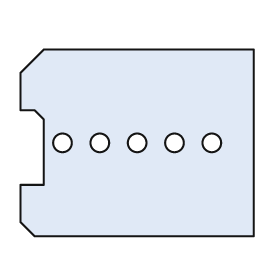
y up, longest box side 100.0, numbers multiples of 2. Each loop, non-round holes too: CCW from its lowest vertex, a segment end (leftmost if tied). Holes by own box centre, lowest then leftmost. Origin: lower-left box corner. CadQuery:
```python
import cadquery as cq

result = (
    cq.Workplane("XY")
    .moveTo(6.0, 0.0)
    .lineTo(100.0, 0.0)
    .lineTo(100.0, 80.0)
    .lineTo(10.0, 80.0)
    .lineTo(0.0, 70.0)
    .lineTo(0.0, 54.0)
    .lineTo(6.0, 54.0)
    .lineTo(10.0, 50.0)
    .lineTo(10.0, 22.0)
    .lineTo(0.0, 22.0)
    .lineTo(0.0, 6.0)
    .close()
    .moveTo(18.0, 40.0)
    .circle(4.0)
    .moveTo(34.0, 40.0)
    .circle(4.0)
    .moveTo(50.0, 40.0)
    .circle(4.0)
    .moveTo(66.0, 40.0)
    .circle(4.0)
    .moveTo(82.0, 40.0)
    .circle(4.0)
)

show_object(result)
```